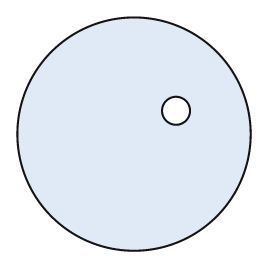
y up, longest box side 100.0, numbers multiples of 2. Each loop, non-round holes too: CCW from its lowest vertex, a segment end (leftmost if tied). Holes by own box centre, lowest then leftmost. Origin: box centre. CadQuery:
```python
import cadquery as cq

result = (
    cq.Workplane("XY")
    .moveTo(0.0, 0.0)
    .circle(50.0)
    .moveTo(18.0, 10.0)
    .circle(6.0)
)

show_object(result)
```